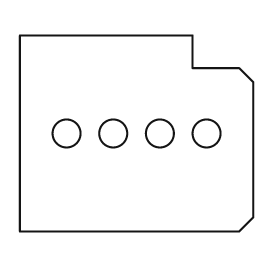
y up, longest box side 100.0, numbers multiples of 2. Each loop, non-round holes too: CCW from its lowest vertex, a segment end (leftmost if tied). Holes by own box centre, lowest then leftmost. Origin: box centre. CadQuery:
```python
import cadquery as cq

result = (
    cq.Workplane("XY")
    .moveTo(-50.0, -42.0)
    .lineTo(44.0, -42.0)
    .lineTo(50.0, -36.0)
    .lineTo(50.0, 22.0)
    .lineTo(44.0, 28.0)
    .lineTo(24.0, 28.0)
    .lineTo(24.0, 42.0)
    .lineTo(-50.0, 42.0)
    .close()
    .moveTo(-30.0, 0.0)
    .circle(6.0)
    .moveTo(-10.0, 0.0)
    .circle(6.0)
    .moveTo(10.0, 0.0)
    .circle(6.0)
    .moveTo(30.0, 0.0)
    .circle(6.0)
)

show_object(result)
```